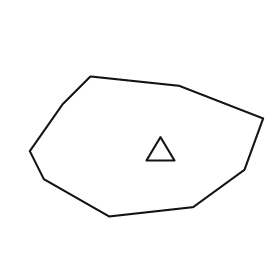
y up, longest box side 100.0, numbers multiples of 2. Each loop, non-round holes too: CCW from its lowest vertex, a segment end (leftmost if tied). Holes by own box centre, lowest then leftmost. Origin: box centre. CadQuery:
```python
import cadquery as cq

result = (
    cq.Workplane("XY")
    .moveTo(-16.0, -30.0)
    .lineTo(20.0, -26.0)
    .lineTo(42.0, -10.0)
    .lineTo(50.0, 12.0)
    .lineTo(14.0, 26.0)
    .lineTo(-24.0, 30.0)
    .lineTo(-36.0, 18.0)
    .lineTo(-50.0, -2.0)
    .lineTo(-44.0, -14.0)
    .close()
    .moveTo(0.0, -6.0)
    .lineTo(12.0, -6.0)
    .lineTo(6.0, 4.0)
    .close()
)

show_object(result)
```